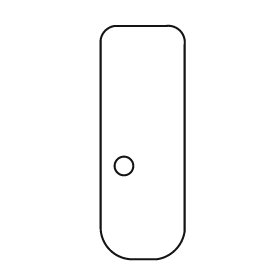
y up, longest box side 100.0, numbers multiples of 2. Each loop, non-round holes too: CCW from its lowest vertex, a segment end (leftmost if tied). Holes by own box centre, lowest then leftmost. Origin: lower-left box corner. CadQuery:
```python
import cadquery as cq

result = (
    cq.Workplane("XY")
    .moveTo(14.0, 0.0)
    .lineTo(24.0, 0.0)
    .threePointArc((32.0, 4.0), (36.0, 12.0))
    .lineTo(36.0, 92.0)
    .threePointArc((34.0, 98.0), (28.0, 100.0))
    .lineTo(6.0, 100.0)
    .threePointArc((2.0, 98.0), (0.0, 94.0))
    .lineTo(0.0, 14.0)
    .threePointArc((4.0, 4.0), (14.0, 0.0))
    .close()
    .moveTo(10.0, 40.0)
    .circle(4.0)
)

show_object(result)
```